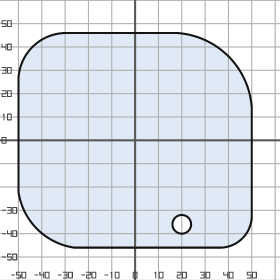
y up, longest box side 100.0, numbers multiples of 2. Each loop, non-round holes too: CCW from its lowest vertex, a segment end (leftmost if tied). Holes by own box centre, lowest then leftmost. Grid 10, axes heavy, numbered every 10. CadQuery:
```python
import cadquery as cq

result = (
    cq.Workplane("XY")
    .moveTo(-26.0, -46.0)
    .lineTo(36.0, -46.0)
    .threePointArc((46.0, -42.0), (50.0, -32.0))
    .lineTo(50.0, 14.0)
    .threePointArc((40.0, 36.0), (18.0, 46.0))
    .lineTo(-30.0, 46.0)
    .threePointArc((-44.0, 40.0), (-50.0, 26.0))
    .lineTo(-50.0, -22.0)
    .threePointArc((-42.0, -38.0), (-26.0, -46.0))
    .close()
    .moveTo(20.0, -36.0)
    .circle(4.0)
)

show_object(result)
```